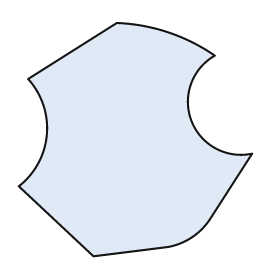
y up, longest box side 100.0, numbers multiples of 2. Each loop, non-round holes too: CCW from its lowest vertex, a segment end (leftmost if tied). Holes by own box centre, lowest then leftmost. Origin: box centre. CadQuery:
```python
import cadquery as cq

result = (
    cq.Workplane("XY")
    .moveTo(-18.0, -50.0)
    .lineTo(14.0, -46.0)
    .threePointArc((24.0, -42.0), (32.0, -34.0))
    .lineTo(50.0, -6.0)
    .threePointArc((24.0, 8.0), (34.0, 36.0))
    .threePointArc((14.0, 46.0), (-8.0, 50.0))
    .lineTo(-46.0, 26.0)
    .threePointArc((-38.0, 2.0), (-50.0, -20.0))
    .close()
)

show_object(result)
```